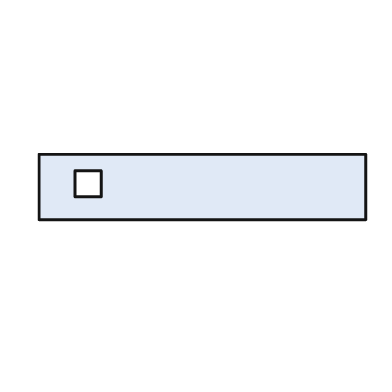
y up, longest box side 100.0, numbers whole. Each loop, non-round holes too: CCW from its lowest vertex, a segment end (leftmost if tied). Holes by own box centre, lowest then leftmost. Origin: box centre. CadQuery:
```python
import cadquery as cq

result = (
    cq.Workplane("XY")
    .moveTo(-50.0, -10.0)
    .lineTo(50.0, -10.0)
    .lineTo(50.0, 10.0)
    .lineTo(-50.0, 10.0)
    .close()
    .moveTo(-39.0, -3.0)
    .lineTo(-31.0, -3.0)
    .lineTo(-31.0, 5.0)
    .lineTo(-39.0, 5.0)
    .close()
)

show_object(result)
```